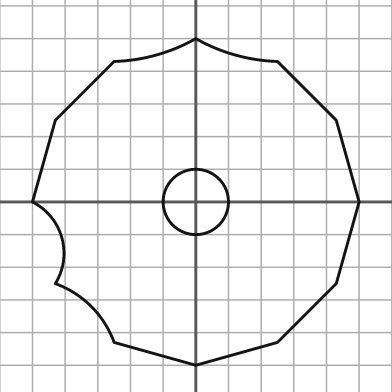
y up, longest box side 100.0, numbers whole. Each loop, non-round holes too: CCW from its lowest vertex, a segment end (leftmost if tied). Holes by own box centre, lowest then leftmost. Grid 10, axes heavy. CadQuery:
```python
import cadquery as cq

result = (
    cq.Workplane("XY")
    .moveTo(0.0, -50.0)
    .lineTo(25.0, -43.0)
    .lineTo(43.0, -25.0)
    .lineTo(50.0, 0.0)
    .lineTo(43.0, 25.0)
    .lineTo(25.0, 43.0)
    .threePointArc((12.0, 45.0), (0.0, 50.0))
    .threePointArc((-12.0, 45.0), (-25.0, 43.0))
    .lineTo(-43.0, 25.0)
    .lineTo(-50.0, 0.0)
    .threePointArc((-41.0, -11.0), (-43.0, -25.0))
    .threePointArc((-32.0, -32.0), (-25.0, -43.0))
    .close()
    .moveTo(0.0, 0.0)
    .circle(10.0)
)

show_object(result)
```